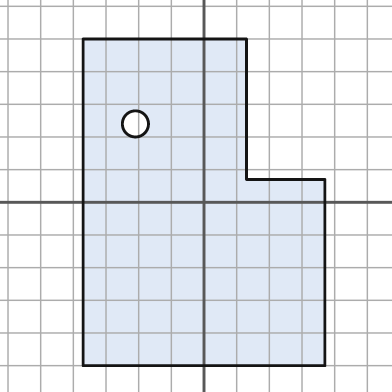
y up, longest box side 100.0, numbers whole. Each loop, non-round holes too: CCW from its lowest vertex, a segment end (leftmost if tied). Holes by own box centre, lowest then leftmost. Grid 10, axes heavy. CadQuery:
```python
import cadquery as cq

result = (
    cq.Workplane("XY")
    .moveTo(-37.0, -50.0)
    .lineTo(37.0, -50.0)
    .lineTo(37.0, 7.0)
    .lineTo(13.0, 7.0)
    .lineTo(13.0, 50.0)
    .lineTo(-37.0, 50.0)
    .close()
    .moveTo(-21.0, 24.0)
    .circle(4.0)
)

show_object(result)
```